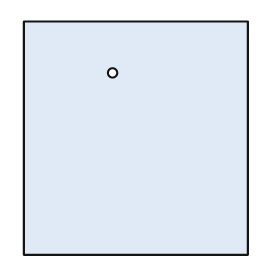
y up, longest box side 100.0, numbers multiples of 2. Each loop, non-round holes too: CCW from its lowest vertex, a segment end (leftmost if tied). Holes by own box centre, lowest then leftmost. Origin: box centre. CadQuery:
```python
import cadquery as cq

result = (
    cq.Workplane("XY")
    .moveTo(-48.0, -50.0)
    .lineTo(48.0, -50.0)
    .lineTo(48.0, 50.0)
    .lineTo(-48.0, 50.0)
    .close()
    .moveTo(-10.0, 28.0)
    .circle(2.0)
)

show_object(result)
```